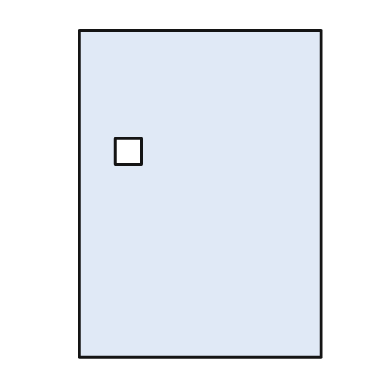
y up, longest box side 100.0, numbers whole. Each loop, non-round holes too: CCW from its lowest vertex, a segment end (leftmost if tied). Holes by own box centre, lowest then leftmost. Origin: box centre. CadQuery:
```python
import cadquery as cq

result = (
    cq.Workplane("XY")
    .moveTo(-37.0, -50.0)
    .lineTo(37.0, -50.0)
    .lineTo(37.0, 50.0)
    .lineTo(-37.0, 50.0)
    .close()
    .moveTo(-26.0, 9.0)
    .lineTo(-18.0, 9.0)
    .lineTo(-18.0, 17.0)
    .lineTo(-26.0, 17.0)
    .close()
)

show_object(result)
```